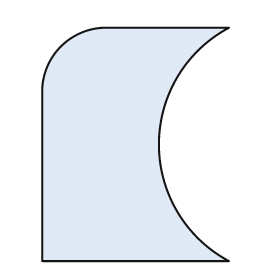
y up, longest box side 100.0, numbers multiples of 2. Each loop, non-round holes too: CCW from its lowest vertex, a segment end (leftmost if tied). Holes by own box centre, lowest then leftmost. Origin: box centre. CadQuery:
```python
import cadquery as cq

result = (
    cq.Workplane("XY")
    .moveTo(-40.0, -50.0)
    .lineTo(40.0, -50.0)
    .threePointArc((10.0, 0.0), (40.0, 50.0))
    .lineTo(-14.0, 50.0)
    .threePointArc((-32.0, 42.0), (-40.0, 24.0))
    .close()
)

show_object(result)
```